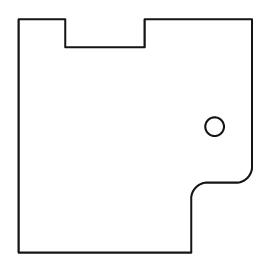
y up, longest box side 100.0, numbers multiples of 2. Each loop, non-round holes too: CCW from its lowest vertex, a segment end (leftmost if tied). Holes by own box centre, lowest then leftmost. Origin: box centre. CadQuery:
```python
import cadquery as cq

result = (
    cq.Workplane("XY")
    .moveTo(-50.0, -50.0)
    .lineTo(24.0, -50.0)
    .lineTo(24.0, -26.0)
    .threePointArc((26.0, -22.0), (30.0, -20.0))
    .lineTo(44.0, -20.0)
    .threePointArc((48.0, -18.0), (50.0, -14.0))
    .lineTo(50.0, 50.0)
    .lineTo(4.0, 50.0)
    .lineTo(4.0, 38.0)
    .lineTo(-30.0, 38.0)
    .lineTo(-30.0, 50.0)
    .lineTo(-50.0, 50.0)
    .close()
    .moveTo(34.0, 4.0)
    .circle(4.0)
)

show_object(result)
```